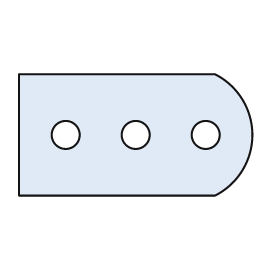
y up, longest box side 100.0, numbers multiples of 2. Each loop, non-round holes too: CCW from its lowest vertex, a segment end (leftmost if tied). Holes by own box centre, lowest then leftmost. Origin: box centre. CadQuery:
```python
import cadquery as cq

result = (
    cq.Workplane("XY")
    .moveTo(-50.0, -26.0)
    .lineTo(34.0, -26.0)
    .threePointArc((50.0, 0.0), (34.0, 26.0))
    .lineTo(-50.0, 26.0)
    .close()
    .moveTo(-30.0, 0.0)
    .circle(6.0)
    .moveTo(0.0, 0.0)
    .circle(6.0)
    .moveTo(30.0, 0.0)
    .circle(6.0)
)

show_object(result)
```